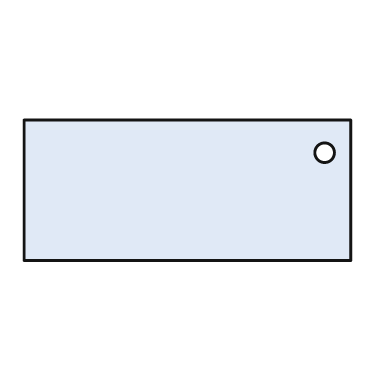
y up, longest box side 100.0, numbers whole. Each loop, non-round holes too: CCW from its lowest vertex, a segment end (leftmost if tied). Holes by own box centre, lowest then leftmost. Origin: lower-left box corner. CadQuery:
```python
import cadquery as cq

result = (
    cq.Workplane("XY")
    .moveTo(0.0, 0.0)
    .lineTo(100.0, 0.0)
    .lineTo(100.0, 43.0)
    .lineTo(0.0, 43.0)
    .close()
    .moveTo(92.0, 33.0)
    .circle(3.0)
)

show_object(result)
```